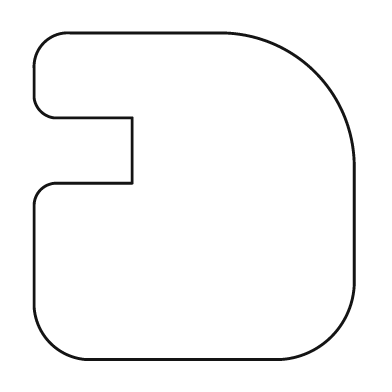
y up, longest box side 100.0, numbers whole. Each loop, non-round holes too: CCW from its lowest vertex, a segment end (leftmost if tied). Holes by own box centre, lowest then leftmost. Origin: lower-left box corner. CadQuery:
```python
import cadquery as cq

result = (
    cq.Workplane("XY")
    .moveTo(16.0, 0.0)
    .lineTo(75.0, 0.0)
    .threePointArc((91.0, 7.0), (98.0, 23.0))
    .lineTo(98.0, 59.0)
    .threePointArc((86.0, 88.0), (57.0, 100.0))
    .lineTo(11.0, 100.0)
    .threePointArc((3.0, 97.0), (0.0, 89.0))
    .lineTo(0.0, 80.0)
    .threePointArc((2.0, 76.0), (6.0, 74.0))
    .lineTo(30.0, 74.0)
    .lineTo(30.0, 54.0)
    .lineTo(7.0, 54.0)
    .threePointArc((2.0, 52.0), (0.0, 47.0))
    .lineTo(0.0, 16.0)
    .threePointArc((5.0, 5.0), (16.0, 0.0))
    .close()
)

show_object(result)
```